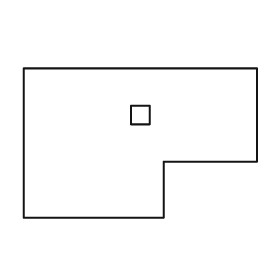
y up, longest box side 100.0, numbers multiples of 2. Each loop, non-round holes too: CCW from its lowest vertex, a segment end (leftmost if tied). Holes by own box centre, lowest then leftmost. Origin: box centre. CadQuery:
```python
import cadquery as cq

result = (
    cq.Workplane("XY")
    .moveTo(-50.0, -32.0)
    .lineTo(10.0, -32.0)
    .lineTo(10.0, -8.0)
    .lineTo(50.0, -8.0)
    .lineTo(50.0, 32.0)
    .lineTo(-50.0, 32.0)
    .close()
    .moveTo(-4.0, 8.0)
    .lineTo(4.0, 8.0)
    .lineTo(4.0, 16.0)
    .lineTo(-4.0, 16.0)
    .close()
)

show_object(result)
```